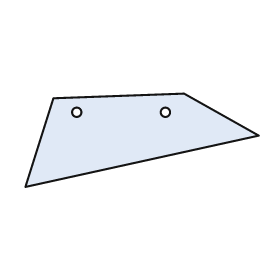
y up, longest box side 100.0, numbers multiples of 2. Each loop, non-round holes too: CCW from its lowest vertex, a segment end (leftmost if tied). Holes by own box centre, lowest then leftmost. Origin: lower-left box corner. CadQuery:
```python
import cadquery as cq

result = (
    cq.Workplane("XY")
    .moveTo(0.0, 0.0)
    .lineTo(100.0, 22.0)
    .lineTo(68.0, 40.0)
    .lineTo(12.0, 38.0)
    .close()
    .moveTo(22.0, 32.0)
    .circle(2.0)
    .moveTo(60.0, 32.0)
    .circle(2.0)
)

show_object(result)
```